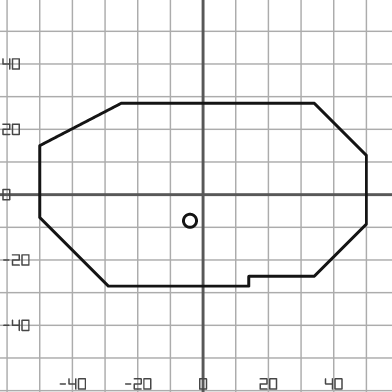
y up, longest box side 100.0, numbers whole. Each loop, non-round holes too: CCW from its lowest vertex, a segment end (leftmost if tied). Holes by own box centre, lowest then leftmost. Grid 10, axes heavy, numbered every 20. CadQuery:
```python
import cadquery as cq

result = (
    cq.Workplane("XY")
    .moveTo(-29.0, -28.0)
    .lineTo(14.0, -28.0)
    .lineTo(14.0, -25.0)
    .lineTo(34.0, -25.0)
    .lineTo(50.0, -9.0)
    .lineTo(50.0, 12.0)
    .lineTo(34.0, 28.0)
    .lineTo(-25.0, 28.0)
    .lineTo(-50.0, 15.0)
    .lineTo(-50.0, -7.0)
    .close()
    .moveTo(-4.0, -8.0)
    .circle(2.0)
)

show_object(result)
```